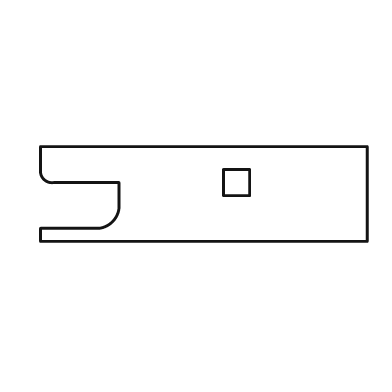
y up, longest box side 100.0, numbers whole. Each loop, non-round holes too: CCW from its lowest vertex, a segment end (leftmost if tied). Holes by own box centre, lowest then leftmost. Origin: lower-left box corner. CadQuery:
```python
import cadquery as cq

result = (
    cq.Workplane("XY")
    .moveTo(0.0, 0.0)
    .lineTo(100.0, 0.0)
    .lineTo(100.0, 29.0)
    .lineTo(0.0, 29.0)
    .lineTo(0.0, 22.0)
    .threePointArc((1.0, 19.0), (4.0, 18.0))
    .lineTo(24.0, 18.0)
    .lineTo(24.0, 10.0)
    .threePointArc((22.0, 6.0), (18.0, 4.0))
    .lineTo(0.0, 4.0)
    .close()
    .moveTo(56.0, 14.0)
    .lineTo(64.0, 14.0)
    .lineTo(64.0, 22.0)
    .lineTo(56.0, 22.0)
    .close()
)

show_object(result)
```